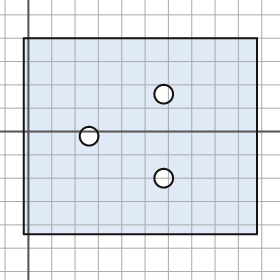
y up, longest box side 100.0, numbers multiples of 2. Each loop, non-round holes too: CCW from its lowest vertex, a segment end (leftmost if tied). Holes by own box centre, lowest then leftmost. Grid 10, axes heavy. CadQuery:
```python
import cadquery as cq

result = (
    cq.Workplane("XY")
    .moveTo(-2.0, -44.0)
    .lineTo(98.0, -44.0)
    .lineTo(98.0, 40.0)
    .lineTo(-2.0, 40.0)
    .close()
    .moveTo(58.0, -20.0)
    .circle(4.0)
    .moveTo(26.0, -2.0)
    .circle(4.0)
    .moveTo(58.0, 16.0)
    .circle(4.0)
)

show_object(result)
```